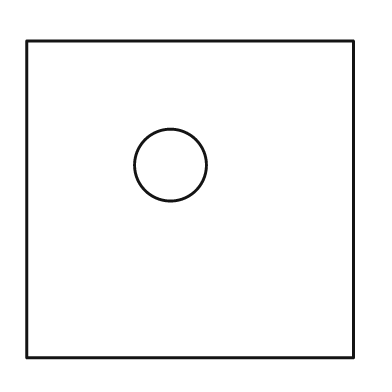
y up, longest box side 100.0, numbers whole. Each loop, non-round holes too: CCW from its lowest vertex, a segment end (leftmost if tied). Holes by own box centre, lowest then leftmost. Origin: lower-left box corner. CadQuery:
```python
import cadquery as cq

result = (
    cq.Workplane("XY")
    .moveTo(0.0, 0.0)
    .lineTo(100.0, 0.0)
    .lineTo(100.0, 97.0)
    .lineTo(0.0, 97.0)
    .close()
    .moveTo(44.0, 59.0)
    .circle(11.0)
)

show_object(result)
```